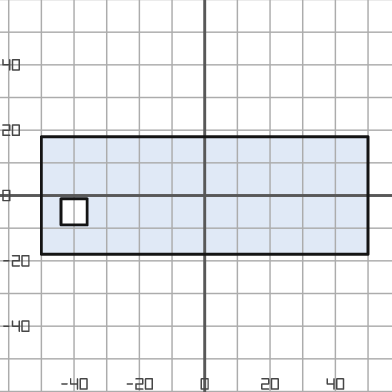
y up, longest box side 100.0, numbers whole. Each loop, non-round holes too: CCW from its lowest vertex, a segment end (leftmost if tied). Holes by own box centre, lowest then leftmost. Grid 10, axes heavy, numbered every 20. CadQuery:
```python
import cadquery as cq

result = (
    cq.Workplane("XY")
    .moveTo(-50.0, -18.0)
    .lineTo(50.0, -18.0)
    .lineTo(50.0, 18.0)
    .lineTo(-50.0, 18.0)
    .close()
    .moveTo(-44.0, -9.0)
    .lineTo(-36.0, -9.0)
    .lineTo(-36.0, -1.0)
    .lineTo(-44.0, -1.0)
    .close()
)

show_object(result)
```